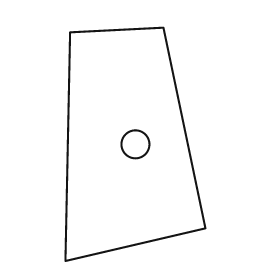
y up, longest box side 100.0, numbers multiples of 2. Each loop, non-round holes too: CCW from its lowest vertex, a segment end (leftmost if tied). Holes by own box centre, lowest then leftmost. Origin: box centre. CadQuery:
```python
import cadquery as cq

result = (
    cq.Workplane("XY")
    .moveTo(-30.0, -50.0)
    .lineTo(30.0, -36.0)
    .lineTo(12.0, 50.0)
    .lineTo(-28.0, 48.0)
    .close()
    .moveTo(0.0, 0.0)
    .circle(6.0)
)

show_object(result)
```